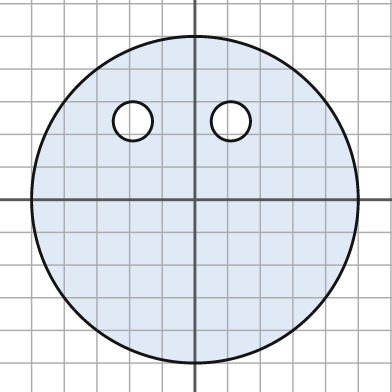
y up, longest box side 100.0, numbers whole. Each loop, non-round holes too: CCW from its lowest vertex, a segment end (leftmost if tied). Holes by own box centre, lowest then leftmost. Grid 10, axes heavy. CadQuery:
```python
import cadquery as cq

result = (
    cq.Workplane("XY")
    .moveTo(0.0, 0.0)
    .circle(50.0)
    .moveTo(-19.0, 24.0)
    .circle(6.0)
    .moveTo(11.0, 24.0)
    .circle(6.0)
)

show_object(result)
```